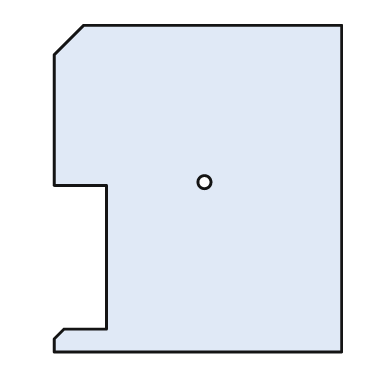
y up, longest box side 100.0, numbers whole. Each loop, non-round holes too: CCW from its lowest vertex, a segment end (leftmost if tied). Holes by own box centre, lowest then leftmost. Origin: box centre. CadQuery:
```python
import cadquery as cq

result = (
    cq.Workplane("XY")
    .moveTo(-44.0, -50.0)
    .lineTo(44.0, -50.0)
    .lineTo(44.0, 50.0)
    .lineTo(-35.0, 50.0)
    .lineTo(-44.0, 41.0)
    .lineTo(-44.0, 1.0)
    .lineTo(-28.0, 1.0)
    .lineTo(-28.0, -43.0)
    .lineTo(-41.0, -43.0)
    .lineTo(-44.0, -46.0)
    .close()
    .moveTo(2.0, 2.0)
    .circle(2.0)
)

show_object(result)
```